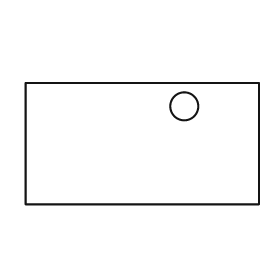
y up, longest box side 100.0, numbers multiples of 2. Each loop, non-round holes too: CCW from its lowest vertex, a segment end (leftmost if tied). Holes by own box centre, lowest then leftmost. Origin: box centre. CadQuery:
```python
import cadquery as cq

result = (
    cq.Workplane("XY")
    .moveTo(-50.0, -26.0)
    .lineTo(50.0, -26.0)
    .lineTo(50.0, 26.0)
    .lineTo(-50.0, 26.0)
    .close()
    .moveTo(18.0, 16.0)
    .circle(6.0)
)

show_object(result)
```